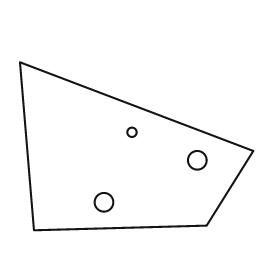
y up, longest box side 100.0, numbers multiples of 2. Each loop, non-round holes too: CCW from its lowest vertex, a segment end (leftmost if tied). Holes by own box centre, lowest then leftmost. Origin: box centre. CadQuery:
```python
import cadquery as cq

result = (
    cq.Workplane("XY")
    .moveTo(-44.0, -36.0)
    .lineTo(30.0, -34.0)
    .lineTo(50.0, -2.0)
    .lineTo(-50.0, 36.0)
    .close()
    .moveTo(-14.0, -24.0)
    .circle(4.0)
    .moveTo(26.0, -6.0)
    .circle(4.0)
    .moveTo(-2.0, 6.0)
    .circle(2.0)
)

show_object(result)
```